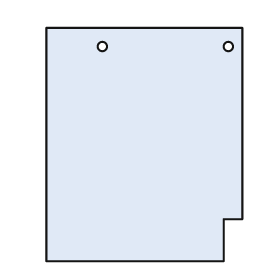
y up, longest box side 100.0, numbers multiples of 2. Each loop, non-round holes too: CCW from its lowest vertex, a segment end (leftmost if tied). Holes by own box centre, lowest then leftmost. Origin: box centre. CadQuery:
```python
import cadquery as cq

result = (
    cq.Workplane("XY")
    .moveTo(-42.0, -50.0)
    .lineTo(34.0, -50.0)
    .lineTo(34.0, -32.0)
    .lineTo(42.0, -32.0)
    .lineTo(42.0, 50.0)
    .lineTo(-42.0, 50.0)
    .close()
    .moveTo(-18.0, 42.0)
    .circle(2.0)
    .moveTo(36.0, 42.0)
    .circle(2.0)
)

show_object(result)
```